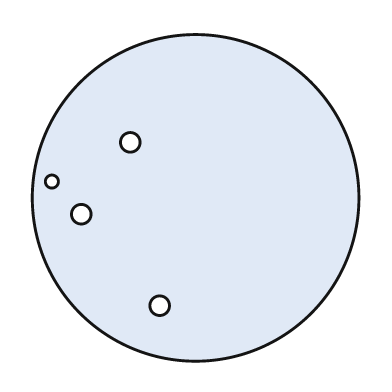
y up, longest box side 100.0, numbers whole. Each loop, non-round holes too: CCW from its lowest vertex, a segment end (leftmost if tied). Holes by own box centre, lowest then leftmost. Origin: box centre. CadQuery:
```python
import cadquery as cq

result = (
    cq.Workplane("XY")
    .moveTo(0.0, 0.0)
    .circle(50.0)
    .moveTo(-11.0, -33.0)
    .circle(3.0)
    .moveTo(-35.0, -5.0)
    .circle(3.0)
    .moveTo(-44.0, 5.0)
    .circle(2.0)
    .moveTo(-20.0, 17.0)
    .circle(3.0)
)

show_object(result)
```